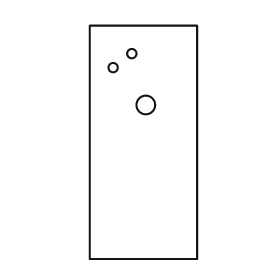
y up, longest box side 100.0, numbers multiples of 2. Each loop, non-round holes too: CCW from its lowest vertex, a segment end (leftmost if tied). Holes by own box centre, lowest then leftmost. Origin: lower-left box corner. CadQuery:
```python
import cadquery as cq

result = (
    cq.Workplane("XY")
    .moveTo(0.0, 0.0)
    .lineTo(46.0, 0.0)
    .lineTo(46.0, 100.0)
    .lineTo(0.0, 100.0)
    .close()
    .moveTo(24.0, 66.0)
    .circle(4.0)
    .moveTo(10.0, 82.0)
    .circle(2.0)
    .moveTo(18.0, 88.0)
    .circle(2.0)
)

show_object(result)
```